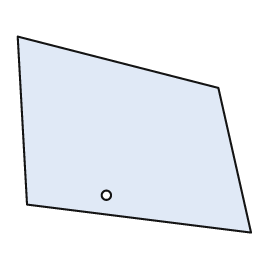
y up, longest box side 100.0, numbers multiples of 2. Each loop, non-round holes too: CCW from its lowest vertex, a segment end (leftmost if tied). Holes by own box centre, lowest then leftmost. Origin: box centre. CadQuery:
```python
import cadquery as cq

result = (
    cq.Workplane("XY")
    .moveTo(50.0, -42.0)
    .lineTo(36.0, 20.0)
    .lineTo(-50.0, 42.0)
    .lineTo(-46.0, -30.0)
    .close()
    .moveTo(-12.0, -26.0)
    .circle(2.0)
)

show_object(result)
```